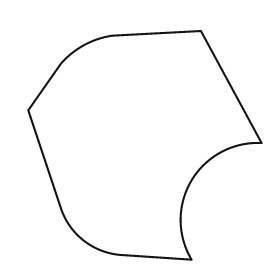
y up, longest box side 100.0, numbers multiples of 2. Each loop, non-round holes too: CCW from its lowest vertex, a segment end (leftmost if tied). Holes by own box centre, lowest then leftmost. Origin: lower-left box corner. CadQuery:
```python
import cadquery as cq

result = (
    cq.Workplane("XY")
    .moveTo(70.0, 0.0)
    .threePointArc((70.0, 34.0), (100.0, 50.0))
    .lineTo(74.0, 98.0)
    .lineTo(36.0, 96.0)
    .threePointArc((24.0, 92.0), (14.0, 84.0))
    .lineTo(0.0, 64.0)
    .lineTo(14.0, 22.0)
    .threePointArc((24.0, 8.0), (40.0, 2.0))
    .close()
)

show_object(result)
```